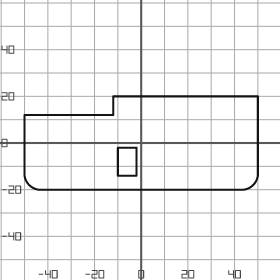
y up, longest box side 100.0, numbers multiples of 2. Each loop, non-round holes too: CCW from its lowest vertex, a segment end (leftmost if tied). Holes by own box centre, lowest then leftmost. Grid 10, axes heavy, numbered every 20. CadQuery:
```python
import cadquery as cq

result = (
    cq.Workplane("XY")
    .moveTo(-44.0, -20.0)
    .lineTo(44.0, -20.0)
    .threePointArc((48.0, -18.0), (50.0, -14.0))
    .lineTo(50.0, 20.0)
    .lineTo(-12.0, 20.0)
    .lineTo(-12.0, 12.0)
    .lineTo(-50.0, 12.0)
    .lineTo(-50.0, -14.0)
    .threePointArc((-48.0, -18.0), (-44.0, -20.0))
    .close()
    .moveTo(-10.0, -14.0)
    .lineTo(-2.0, -14.0)
    .lineTo(-2.0, -2.0)
    .lineTo(-10.0, -2.0)
    .close()
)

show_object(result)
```